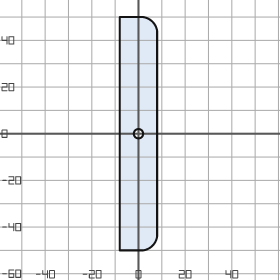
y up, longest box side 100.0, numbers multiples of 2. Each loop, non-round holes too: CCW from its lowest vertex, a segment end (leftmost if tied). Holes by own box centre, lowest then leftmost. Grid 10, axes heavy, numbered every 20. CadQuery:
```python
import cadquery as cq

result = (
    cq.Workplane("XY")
    .moveTo(-8.0, -50.0)
    .lineTo(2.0, -50.0)
    .threePointArc((6.0, -48.0), (8.0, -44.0))
    .lineTo(8.0, 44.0)
    .threePointArc((6.0, 48.0), (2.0, 50.0))
    .lineTo(-8.0, 50.0)
    .close()
    .moveTo(0.0, 0.0)
    .circle(2.0)
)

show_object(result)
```